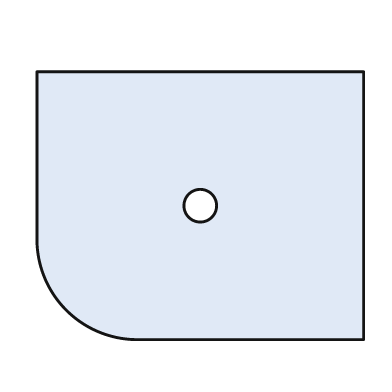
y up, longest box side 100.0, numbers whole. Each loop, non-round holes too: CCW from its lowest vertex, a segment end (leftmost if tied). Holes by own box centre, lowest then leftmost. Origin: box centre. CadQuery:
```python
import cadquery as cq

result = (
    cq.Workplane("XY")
    .moveTo(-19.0, -41.0)
    .lineTo(50.0, -41.0)
    .lineTo(50.0, 41.0)
    .lineTo(-50.0, 41.0)
    .lineTo(-50.0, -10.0)
    .threePointArc((-41.0, -32.0), (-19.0, -41.0))
    .close()
    .moveTo(0.0, 0.0)
    .circle(5.0)
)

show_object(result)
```